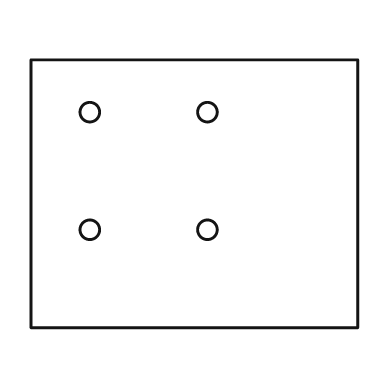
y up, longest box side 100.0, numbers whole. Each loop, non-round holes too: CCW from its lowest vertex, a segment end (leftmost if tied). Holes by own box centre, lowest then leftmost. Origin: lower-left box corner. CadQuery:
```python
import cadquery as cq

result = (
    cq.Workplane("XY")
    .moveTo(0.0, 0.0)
    .lineTo(100.0, 0.0)
    .lineTo(100.0, 82.0)
    .lineTo(0.0, 82.0)
    .close()
    .moveTo(18.0, 30.0)
    .circle(3.0)
    .moveTo(54.0, 30.0)
    .circle(3.0)
    .moveTo(18.0, 66.0)
    .circle(3.0)
    .moveTo(54.0, 66.0)
    .circle(3.0)
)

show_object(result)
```